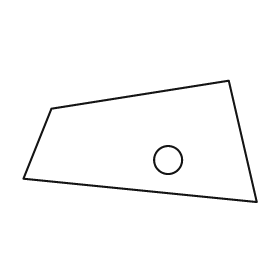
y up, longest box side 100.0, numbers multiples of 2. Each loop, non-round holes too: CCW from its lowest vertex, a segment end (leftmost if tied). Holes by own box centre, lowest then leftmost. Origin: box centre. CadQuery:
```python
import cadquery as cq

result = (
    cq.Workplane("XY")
    .moveTo(50.0, -26.0)
    .lineTo(38.0, 26.0)
    .lineTo(-38.0, 14.0)
    .lineTo(-50.0, -16.0)
    .close()
    .moveTo(12.0, -8.0)
    .circle(6.0)
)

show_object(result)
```